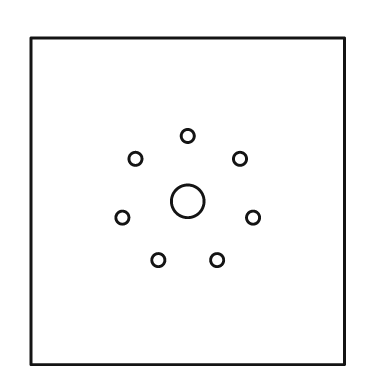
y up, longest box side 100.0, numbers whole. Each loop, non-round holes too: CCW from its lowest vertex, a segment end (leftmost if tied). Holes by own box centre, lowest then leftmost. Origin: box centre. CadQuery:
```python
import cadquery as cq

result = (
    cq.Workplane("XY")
    .moveTo(-48.0, -50.0)
    .lineTo(48.0, -50.0)
    .lineTo(48.0, 50.0)
    .lineTo(-48.0, 50.0)
    .close()
    .moveTo(-9.0, -18.0)
    .circle(2.0)
    .moveTo(9.0, -18.0)
    .circle(2.0)
    .moveTo(-20.0, -5.0)
    .circle(2.0)
    .moveTo(20.0, -5.0)
    .circle(2.0)
    .moveTo(0.0, 0.0)
    .circle(5.0)
    .moveTo(-16.0, 13.0)
    .circle(2.0)
    .moveTo(16.0, 13.0)
    .circle(2.0)
    .moveTo(0.0, 20.0)
    .circle(2.0)
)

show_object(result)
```